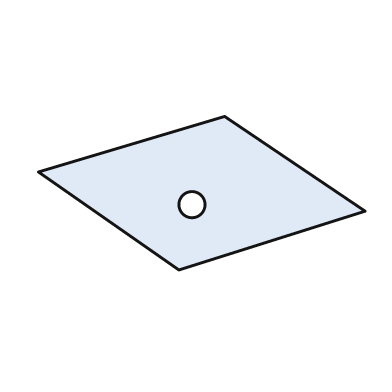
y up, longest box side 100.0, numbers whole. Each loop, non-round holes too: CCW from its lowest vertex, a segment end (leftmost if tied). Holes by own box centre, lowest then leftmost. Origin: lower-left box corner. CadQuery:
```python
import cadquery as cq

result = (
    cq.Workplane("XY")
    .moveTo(43.0, 0.0)
    .lineTo(100.0, 18.0)
    .lineTo(57.0, 47.0)
    .lineTo(0.0, 30.0)
    .close()
    .moveTo(47.0, 20.0)
    .circle(4.0)
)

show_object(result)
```